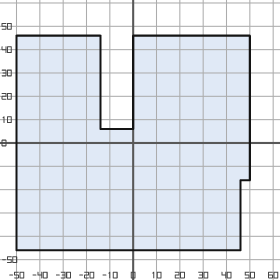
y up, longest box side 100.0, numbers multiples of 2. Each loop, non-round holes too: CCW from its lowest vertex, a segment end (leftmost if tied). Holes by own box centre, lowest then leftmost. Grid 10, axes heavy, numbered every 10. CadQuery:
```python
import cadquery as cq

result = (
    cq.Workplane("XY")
    .moveTo(-50.0, -46.0)
    .lineTo(46.0, -46.0)
    .lineTo(46.0, -16.0)
    .lineTo(50.0, -16.0)
    .lineTo(50.0, 46.0)
    .lineTo(0.0, 46.0)
    .lineTo(0.0, 6.0)
    .lineTo(-14.0, 6.0)
    .lineTo(-14.0, 46.0)
    .lineTo(-50.0, 46.0)
    .close()
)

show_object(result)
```